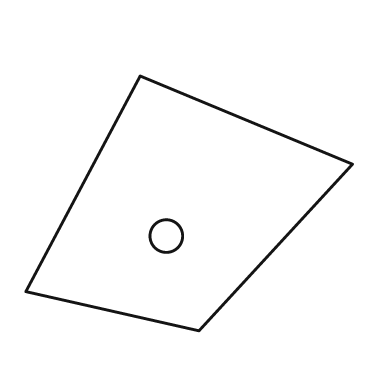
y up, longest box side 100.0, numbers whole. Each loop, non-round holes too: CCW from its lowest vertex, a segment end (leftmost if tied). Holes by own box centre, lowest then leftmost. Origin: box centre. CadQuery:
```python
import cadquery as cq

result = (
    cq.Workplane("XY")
    .moveTo(3.0, -39.0)
    .lineTo(50.0, 12.0)
    .lineTo(-15.0, 39.0)
    .lineTo(-50.0, -27.0)
    .close()
    .moveTo(-7.0, -10.0)
    .circle(5.0)
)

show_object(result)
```